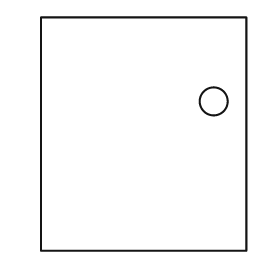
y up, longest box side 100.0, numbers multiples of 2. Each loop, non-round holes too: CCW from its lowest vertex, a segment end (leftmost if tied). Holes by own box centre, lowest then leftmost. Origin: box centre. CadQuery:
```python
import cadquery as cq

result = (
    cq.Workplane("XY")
    .moveTo(-44.0, -50.0)
    .lineTo(44.0, -50.0)
    .lineTo(44.0, 50.0)
    .lineTo(-44.0, 50.0)
    .close()
    .moveTo(30.0, 14.0)
    .circle(6.0)
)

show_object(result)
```